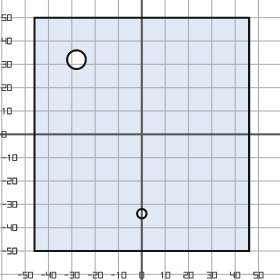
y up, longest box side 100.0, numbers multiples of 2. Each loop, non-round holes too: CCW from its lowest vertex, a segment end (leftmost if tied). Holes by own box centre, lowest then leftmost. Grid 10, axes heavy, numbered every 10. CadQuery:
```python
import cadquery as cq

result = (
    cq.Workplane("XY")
    .moveTo(-46.0, -50.0)
    .lineTo(46.0, -50.0)
    .lineTo(46.0, 50.0)
    .lineTo(-46.0, 50.0)
    .close()
    .moveTo(0.0, -34.0)
    .circle(2.0)
    .moveTo(-28.0, 32.0)
    .circle(4.0)
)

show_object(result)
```